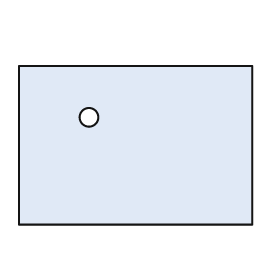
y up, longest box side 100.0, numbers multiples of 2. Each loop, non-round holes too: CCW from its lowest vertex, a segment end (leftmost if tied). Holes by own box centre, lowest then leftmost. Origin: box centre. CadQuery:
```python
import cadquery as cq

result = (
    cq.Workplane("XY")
    .moveTo(-50.0, -34.0)
    .lineTo(50.0, -34.0)
    .lineTo(50.0, 34.0)
    .lineTo(-50.0, 34.0)
    .close()
    .moveTo(-20.0, 12.0)
    .circle(4.0)
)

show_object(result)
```